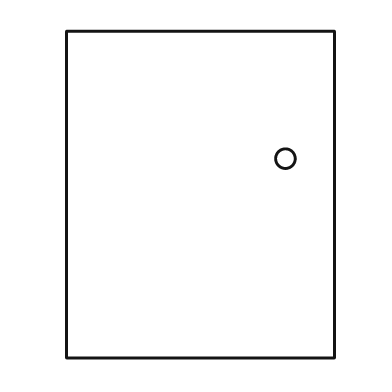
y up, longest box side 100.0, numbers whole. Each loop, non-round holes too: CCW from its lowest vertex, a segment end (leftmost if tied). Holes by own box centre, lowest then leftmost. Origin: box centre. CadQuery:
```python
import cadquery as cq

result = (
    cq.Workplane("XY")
    .moveTo(-41.0, -50.0)
    .lineTo(41.0, -50.0)
    .lineTo(41.0, 50.0)
    .lineTo(-41.0, 50.0)
    .close()
    .moveTo(26.0, 11.0)
    .circle(3.0)
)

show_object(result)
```